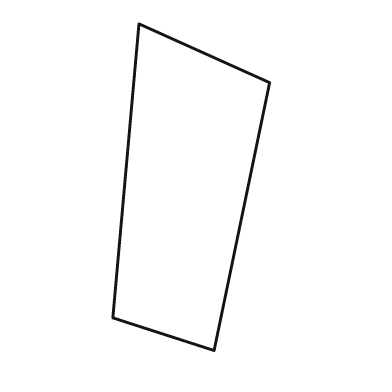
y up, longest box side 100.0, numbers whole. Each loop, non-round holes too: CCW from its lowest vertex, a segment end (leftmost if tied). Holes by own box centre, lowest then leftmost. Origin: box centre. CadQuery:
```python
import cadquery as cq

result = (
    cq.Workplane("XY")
    .moveTo(7.0, -50.0)
    .lineTo(24.0, 32.0)
    .lineTo(-16.0, 50.0)
    .lineTo(-24.0, -40.0)
    .close()
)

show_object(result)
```